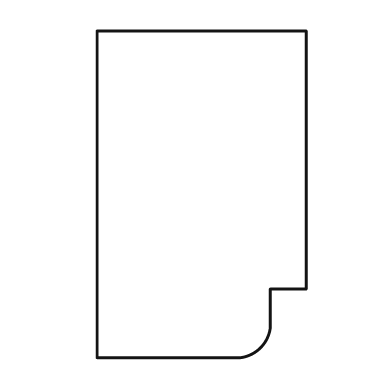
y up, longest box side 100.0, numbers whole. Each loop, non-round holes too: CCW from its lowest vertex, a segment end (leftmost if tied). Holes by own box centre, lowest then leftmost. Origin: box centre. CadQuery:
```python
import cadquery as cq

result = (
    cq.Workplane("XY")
    .moveTo(-32.0, -50.0)
    .lineTo(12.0, -50.0)
    .threePointArc((18.0, -47.0), (21.0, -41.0))
    .lineTo(21.0, -29.0)
    .lineTo(32.0, -29.0)
    .lineTo(32.0, 50.0)
    .lineTo(-32.0, 50.0)
    .close()
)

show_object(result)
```